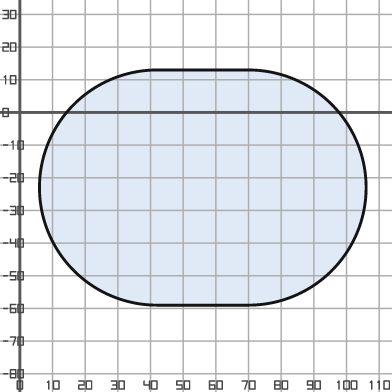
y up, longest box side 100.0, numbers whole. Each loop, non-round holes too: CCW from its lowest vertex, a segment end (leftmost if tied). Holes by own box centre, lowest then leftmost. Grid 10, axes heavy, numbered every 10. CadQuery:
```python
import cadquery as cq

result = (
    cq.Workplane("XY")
    .moveTo(42.0, -59.0)
    .lineTo(70.0, -59.0)
    .threePointArc((106.0, -23.0), (70.0, 13.0))
    .lineTo(42.0, 13.0)
    .threePointArc((6.0, -23.0), (42.0, -59.0))
    .close()
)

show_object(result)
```